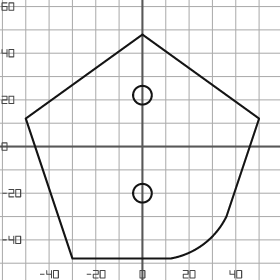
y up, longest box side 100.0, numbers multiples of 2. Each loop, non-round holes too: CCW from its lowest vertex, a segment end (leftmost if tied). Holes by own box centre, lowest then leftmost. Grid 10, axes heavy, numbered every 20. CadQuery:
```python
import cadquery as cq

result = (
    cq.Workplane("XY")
    .moveTo(-30.0, -48.0)
    .lineTo(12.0, -48.0)
    .threePointArc((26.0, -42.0), (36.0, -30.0))
    .lineTo(50.0, 12.0)
    .lineTo(0.0, 48.0)
    .lineTo(-50.0, 12.0)
    .close()
    .moveTo(0.0, -20.0)
    .circle(4.0)
    .moveTo(0.0, 22.0)
    .circle(4.0)
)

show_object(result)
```